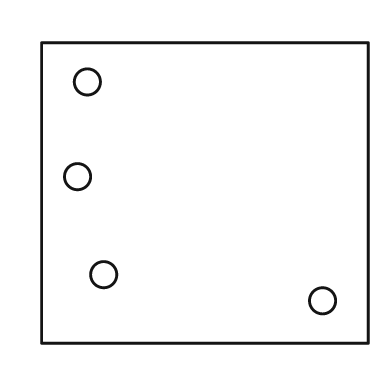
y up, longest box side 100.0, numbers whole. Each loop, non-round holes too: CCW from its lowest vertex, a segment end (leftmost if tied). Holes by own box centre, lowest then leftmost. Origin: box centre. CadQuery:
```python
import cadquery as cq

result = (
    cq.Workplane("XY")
    .moveTo(-50.0, -46.0)
    .lineTo(50.0, -46.0)
    .lineTo(50.0, 46.0)
    .lineTo(-50.0, 46.0)
    .close()
    .moveTo(36.0, -33.0)
    .circle(4.0)
    .moveTo(-31.0, -25.0)
    .circle(4.0)
    .moveTo(-39.0, 5.0)
    .circle(4.0)
    .moveTo(-36.0, 34.0)
    .circle(4.0)
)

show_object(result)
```